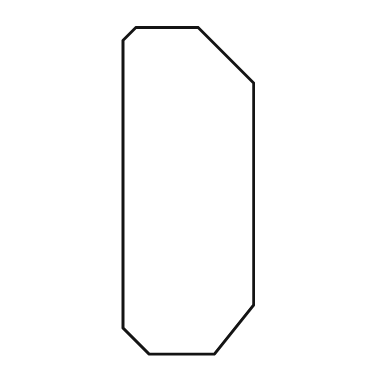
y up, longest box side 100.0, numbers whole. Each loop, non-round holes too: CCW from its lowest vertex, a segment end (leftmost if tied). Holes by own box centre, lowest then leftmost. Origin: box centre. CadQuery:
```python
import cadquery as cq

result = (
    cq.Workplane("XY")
    .moveTo(-12.0, -50.0)
    .lineTo(8.0, -50.0)
    .lineTo(20.0, -35.0)
    .lineTo(20.0, 33.0)
    .lineTo(3.0, 50.0)
    .lineTo(-16.0, 50.0)
    .lineTo(-20.0, 46.0)
    .lineTo(-20.0, -42.0)
    .close()
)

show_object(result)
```